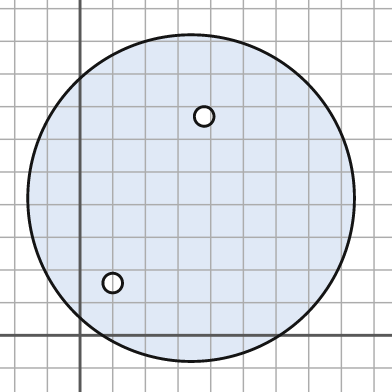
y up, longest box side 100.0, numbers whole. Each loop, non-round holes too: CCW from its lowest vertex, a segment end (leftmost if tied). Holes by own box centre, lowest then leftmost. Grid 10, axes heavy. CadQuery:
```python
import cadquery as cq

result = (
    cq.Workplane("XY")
    .moveTo(34.0, 42.0)
    .circle(50.0)
    .moveTo(10.0, 16.0)
    .circle(3.0)
    .moveTo(38.0, 67.0)
    .circle(3.0)
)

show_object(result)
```